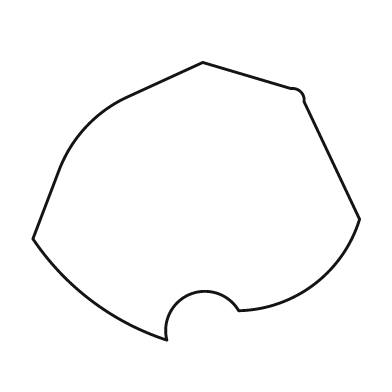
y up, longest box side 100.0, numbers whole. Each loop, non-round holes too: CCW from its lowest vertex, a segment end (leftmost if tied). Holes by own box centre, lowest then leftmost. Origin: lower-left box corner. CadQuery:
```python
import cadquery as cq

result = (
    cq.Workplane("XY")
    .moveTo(41.0, 0.0)
    .threePointArc((48.0, 14.0), (63.0, 9.0))
    .threePointArc((86.0, 17.0), (100.0, 37.0))
    .lineTo(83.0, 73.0)
    .threePointArc((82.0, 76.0), (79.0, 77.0))
    .lineTo(52.0, 85.0)
    .lineTo(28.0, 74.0)
    .threePointArc((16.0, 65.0), (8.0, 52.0))
    .lineTo(0.0, 31.0)
    .threePointArc((18.0, 12.0), (41.0, 0.0))
    .close()
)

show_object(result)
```